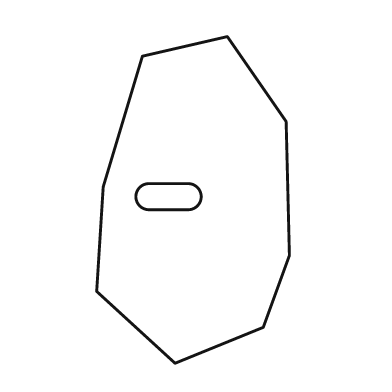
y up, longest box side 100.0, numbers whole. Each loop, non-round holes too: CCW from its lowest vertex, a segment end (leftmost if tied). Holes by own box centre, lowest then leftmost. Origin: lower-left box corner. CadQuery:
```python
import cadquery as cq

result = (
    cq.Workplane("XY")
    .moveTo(24.0, 0.0)
    .lineTo(51.0, 11.0)
    .lineTo(59.0, 33.0)
    .lineTo(58.0, 74.0)
    .lineTo(40.0, 100.0)
    .lineTo(14.0, 94.0)
    .lineTo(2.0, 54.0)
    .lineTo(0.0, 22.0)
    .close()
    .moveTo(16.0, 47.0)
    .lineTo(28.0, 47.0)
    .threePointArc((32.0, 51.0), (28.0, 55.0))
    .lineTo(16.0, 55.0)
    .threePointArc((12.0, 51.0), (16.0, 47.0))
    .close()
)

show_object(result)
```